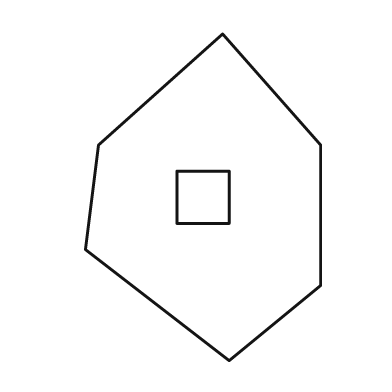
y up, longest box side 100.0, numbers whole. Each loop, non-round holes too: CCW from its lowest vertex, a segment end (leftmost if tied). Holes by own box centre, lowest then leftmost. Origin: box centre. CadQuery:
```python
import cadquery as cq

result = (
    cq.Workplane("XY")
    .moveTo(8.0, -50.0)
    .lineTo(36.0, -27.0)
    .lineTo(36.0, 16.0)
    .lineTo(6.0, 50.0)
    .lineTo(-32.0, 16.0)
    .lineTo(-36.0, -16.0)
    .close()
    .moveTo(-8.0, -8.0)
    .lineTo(8.0, -8.0)
    .lineTo(8.0, 8.0)
    .lineTo(-8.0, 8.0)
    .close()
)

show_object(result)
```